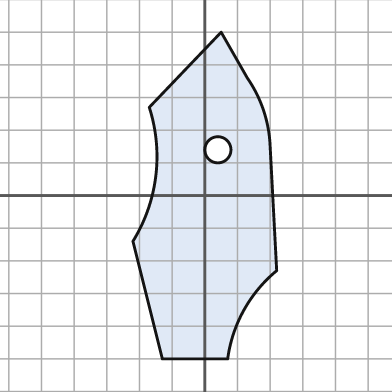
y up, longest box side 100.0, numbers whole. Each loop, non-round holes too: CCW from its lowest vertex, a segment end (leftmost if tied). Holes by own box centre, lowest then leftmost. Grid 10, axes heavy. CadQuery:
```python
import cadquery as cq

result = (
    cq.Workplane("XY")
    .moveTo(-13.0, -50.0)
    .lineTo(7.0, -50.0)
    .threePointArc((12.0, -35.0), (22.0, -23.0))
    .lineTo(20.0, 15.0)
    .threePointArc((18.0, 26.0), (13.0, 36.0))
    .lineTo(5.0, 50.0)
    .lineTo(-17.0, 27.0)
    .threePointArc((-15.0, 6.0), (-22.0, -14.0))
    .close()
    .moveTo(4.0, 14.0)
    .circle(4.0)
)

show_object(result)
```